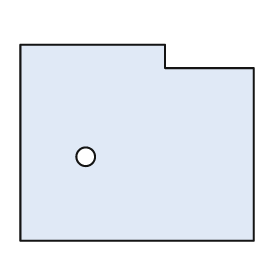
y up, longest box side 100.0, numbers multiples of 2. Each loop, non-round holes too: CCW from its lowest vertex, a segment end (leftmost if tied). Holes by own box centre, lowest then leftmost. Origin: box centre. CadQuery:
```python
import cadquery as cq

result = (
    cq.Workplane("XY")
    .moveTo(-50.0, -42.0)
    .lineTo(50.0, -42.0)
    .lineTo(50.0, 32.0)
    .lineTo(12.0, 32.0)
    .lineTo(12.0, 42.0)
    .lineTo(-50.0, 42.0)
    .close()
    .moveTo(-22.0, -6.0)
    .circle(4.0)
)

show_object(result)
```